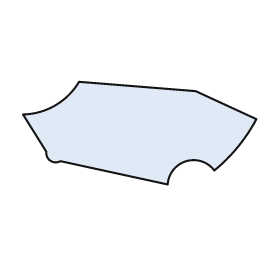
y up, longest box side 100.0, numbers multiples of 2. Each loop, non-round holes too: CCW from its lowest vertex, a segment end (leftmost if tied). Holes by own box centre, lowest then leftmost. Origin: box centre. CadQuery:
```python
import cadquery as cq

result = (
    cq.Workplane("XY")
    .moveTo(12.0, -22.0)
    .threePointArc((20.0, -12.0), (32.0, -16.0))
    .threePointArc((42.0, -6.0), (50.0, 6.0))
    .lineTo(24.0, 18.0)
    .lineTo(-26.0, 22.0)
    .threePointArc((-36.0, 12.0), (-50.0, 8.0))
    .lineTo(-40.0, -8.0)
    .threePointArc((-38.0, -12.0), (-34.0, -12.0))
    .close()
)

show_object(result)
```